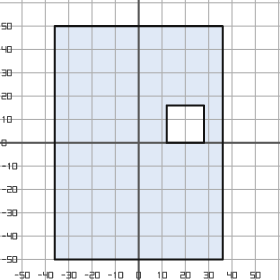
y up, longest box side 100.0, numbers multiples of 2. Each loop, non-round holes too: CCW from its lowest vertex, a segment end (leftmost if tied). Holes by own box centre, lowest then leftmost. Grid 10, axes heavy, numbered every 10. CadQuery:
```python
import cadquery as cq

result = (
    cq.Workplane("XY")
    .moveTo(-36.0, -50.0)
    .lineTo(36.0, -50.0)
    .lineTo(36.0, 50.0)
    .lineTo(-36.0, 50.0)
    .close()
    .moveTo(12.0, 0.0)
    .lineTo(28.0, 0.0)
    .lineTo(28.0, 16.0)
    .lineTo(12.0, 16.0)
    .close()
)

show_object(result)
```